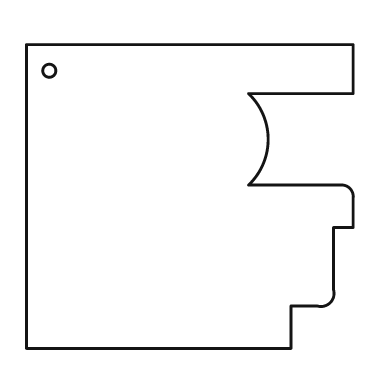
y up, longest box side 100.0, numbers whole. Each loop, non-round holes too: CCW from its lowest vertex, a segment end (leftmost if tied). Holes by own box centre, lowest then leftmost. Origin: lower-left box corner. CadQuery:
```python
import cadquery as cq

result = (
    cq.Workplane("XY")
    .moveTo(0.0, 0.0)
    .lineTo(81.0, 0.0)
    .lineTo(81.0, 13.0)
    .lineTo(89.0, 13.0)
    .threePointArc((93.0, 14.0), (94.0, 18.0))
    .lineTo(94.0, 37.0)
    .lineTo(100.0, 37.0)
    .lineTo(100.0, 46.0)
    .threePointArc((99.0, 49.0), (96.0, 50.0))
    .lineTo(68.0, 50.0)
    .threePointArc((74.0, 64.0), (68.0, 78.0))
    .lineTo(100.0, 78.0)
    .lineTo(100.0, 93.0)
    .lineTo(0.0, 93.0)
    .close()
    .moveTo(7.0, 85.0)
    .circle(2.0)
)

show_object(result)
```